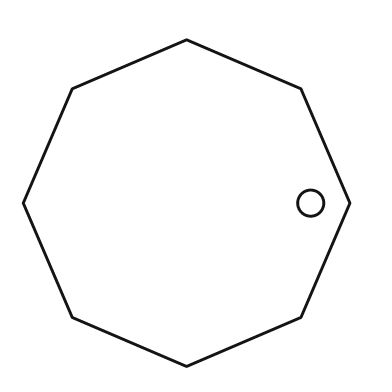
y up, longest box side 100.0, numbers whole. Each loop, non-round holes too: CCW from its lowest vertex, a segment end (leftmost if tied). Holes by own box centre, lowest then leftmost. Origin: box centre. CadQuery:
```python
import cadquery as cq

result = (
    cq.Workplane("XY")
    .moveTo(0.0, -50.0)
    .lineTo(35.0, -35.0)
    .lineTo(50.0, 0.0)
    .lineTo(35.0, 35.0)
    .lineTo(0.0, 50.0)
    .lineTo(-35.0, 35.0)
    .lineTo(-50.0, 0.0)
    .lineTo(-35.0, -35.0)
    .close()
    .moveTo(38.0, 0.0)
    .circle(4.0)
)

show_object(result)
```